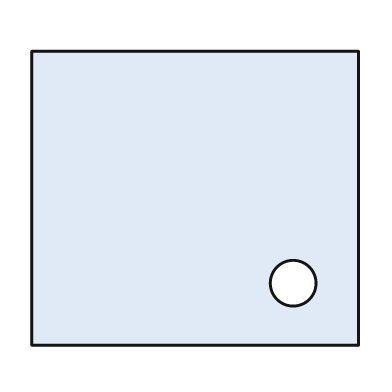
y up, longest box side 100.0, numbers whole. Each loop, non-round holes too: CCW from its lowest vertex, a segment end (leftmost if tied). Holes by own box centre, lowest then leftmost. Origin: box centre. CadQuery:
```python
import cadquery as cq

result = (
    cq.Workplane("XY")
    .moveTo(-50.0, -45.0)
    .lineTo(50.0, -45.0)
    .lineTo(50.0, 45.0)
    .lineTo(-50.0, 45.0)
    .close()
    .moveTo(30.0, -26.0)
    .circle(7.0)
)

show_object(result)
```